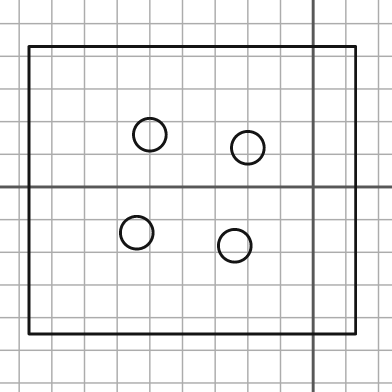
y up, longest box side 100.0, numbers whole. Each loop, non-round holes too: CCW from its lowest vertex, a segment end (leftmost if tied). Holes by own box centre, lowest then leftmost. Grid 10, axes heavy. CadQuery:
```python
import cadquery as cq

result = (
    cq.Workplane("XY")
    .moveTo(-87.0, -45.0)
    .lineTo(13.0, -45.0)
    .lineTo(13.0, 43.0)
    .lineTo(-87.0, 43.0)
    .close()
    .moveTo(-24.0, -18.0)
    .circle(5.0)
    .moveTo(-54.0, -14.0)
    .circle(5.0)
    .moveTo(-20.0, 12.0)
    .circle(5.0)
    .moveTo(-50.0, 16.0)
    .circle(5.0)
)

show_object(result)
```